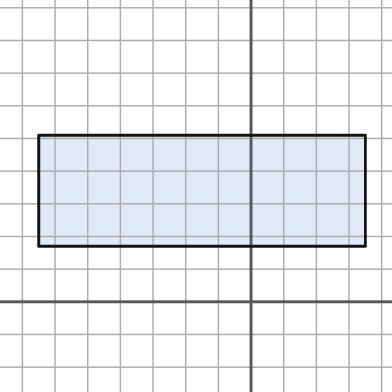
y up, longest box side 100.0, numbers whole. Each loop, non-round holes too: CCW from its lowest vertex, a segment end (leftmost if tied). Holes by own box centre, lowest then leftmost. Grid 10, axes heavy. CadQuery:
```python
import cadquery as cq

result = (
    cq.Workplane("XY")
    .moveTo(-65.0, 17.0)
    .lineTo(35.0, 17.0)
    .lineTo(35.0, 51.0)
    .lineTo(-65.0, 51.0)
    .close()
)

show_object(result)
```